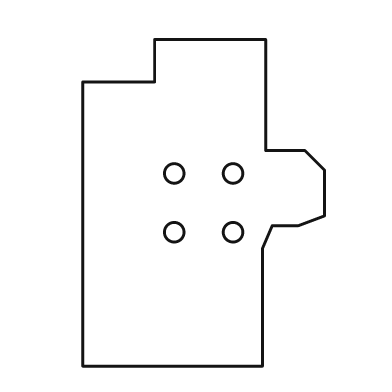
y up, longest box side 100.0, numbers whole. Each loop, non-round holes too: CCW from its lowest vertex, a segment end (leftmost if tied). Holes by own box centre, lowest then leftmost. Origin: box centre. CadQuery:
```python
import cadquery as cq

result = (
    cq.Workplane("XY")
    .moveTo(-37.0, -50.0)
    .lineTo(18.0, -50.0)
    .lineTo(18.0, -14.0)
    .lineTo(21.0, -7.0)
    .lineTo(29.0, -7.0)
    .lineTo(37.0, -4.0)
    .lineTo(37.0, 10.0)
    .lineTo(31.0, 16.0)
    .lineTo(19.0, 16.0)
    .lineTo(19.0, 50.0)
    .lineTo(-15.0, 50.0)
    .lineTo(-15.0, 37.0)
    .lineTo(-37.0, 37.0)
    .close()
    .moveTo(-9.0, -9.0)
    .circle(3.0)
    .moveTo(9.0, -9.0)
    .circle(3.0)
    .moveTo(-9.0, 9.0)
    .circle(3.0)
    .moveTo(9.0, 9.0)
    .circle(3.0)
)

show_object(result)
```